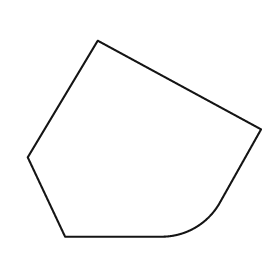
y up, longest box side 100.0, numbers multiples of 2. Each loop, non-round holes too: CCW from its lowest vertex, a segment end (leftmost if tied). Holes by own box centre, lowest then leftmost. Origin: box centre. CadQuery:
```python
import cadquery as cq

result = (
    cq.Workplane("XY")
    .moveTo(-34.0, -42.0)
    .lineTo(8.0, -42.0)
    .threePointArc((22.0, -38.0), (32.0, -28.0))
    .lineTo(50.0, 4.0)
    .lineTo(-20.0, 42.0)
    .lineTo(-50.0, -8.0)
    .close()
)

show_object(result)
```